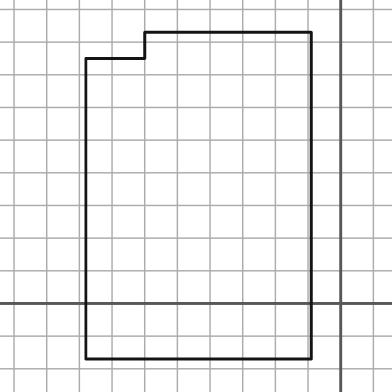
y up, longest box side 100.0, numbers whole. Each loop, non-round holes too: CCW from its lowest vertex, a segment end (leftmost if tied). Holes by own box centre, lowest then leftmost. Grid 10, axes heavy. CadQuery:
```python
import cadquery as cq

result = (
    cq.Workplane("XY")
    .moveTo(-78.0, -17.0)
    .lineTo(-9.0, -17.0)
    .lineTo(-9.0, 83.0)
    .lineTo(-60.0, 83.0)
    .lineTo(-60.0, 75.0)
    .lineTo(-78.0, 75.0)
    .close()
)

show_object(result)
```